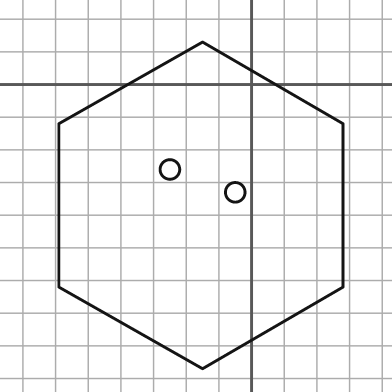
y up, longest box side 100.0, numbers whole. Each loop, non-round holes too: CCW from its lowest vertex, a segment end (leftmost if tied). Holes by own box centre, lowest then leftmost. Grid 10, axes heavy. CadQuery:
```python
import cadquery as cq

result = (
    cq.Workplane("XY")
    .moveTo(-15.0, -87.0)
    .lineTo(28.0, -62.0)
    .lineTo(28.0, -12.0)
    .lineTo(-15.0, 13.0)
    .lineTo(-59.0, -12.0)
    .lineTo(-59.0, -62.0)
    .close()
    .moveTo(-5.0, -33.0)
    .circle(3.0)
    .moveTo(-25.0, -26.0)
    .circle(3.0)
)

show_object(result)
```